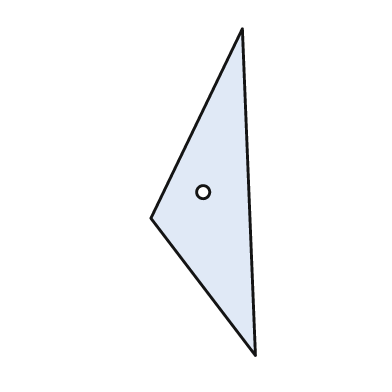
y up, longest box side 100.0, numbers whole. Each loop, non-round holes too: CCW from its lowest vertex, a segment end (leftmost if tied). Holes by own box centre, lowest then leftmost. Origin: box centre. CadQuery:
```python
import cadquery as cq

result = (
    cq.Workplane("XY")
    .moveTo(16.0, -50.0)
    .lineTo(12.0, 50.0)
    .lineTo(-16.0, -8.0)
    .close()
    .moveTo(0.0, 0.0)
    .circle(2.0)
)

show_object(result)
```